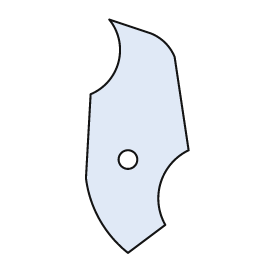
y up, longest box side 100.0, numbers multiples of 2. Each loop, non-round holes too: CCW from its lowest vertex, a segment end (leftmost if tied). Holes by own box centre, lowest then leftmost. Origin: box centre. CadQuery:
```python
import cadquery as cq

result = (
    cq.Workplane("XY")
    .moveTo(-4.0, -50.0)
    .lineTo(12.0, -38.0)
    .threePointArc((10.0, -20.0), (22.0, -6.0))
    .lineTo(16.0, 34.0)
    .threePointArc((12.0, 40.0), (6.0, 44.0))
    .lineTo(-12.0, 50.0)
    .threePointArc((-8.0, 32.0), (-20.0, 18.0))
    .lineTo(-22.0, -18.0)
    .threePointArc((-16.0, -36.0), (-4.0, -50.0))
    .close()
    .moveTo(-4.0, -10.0)
    .circle(4.0)
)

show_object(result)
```